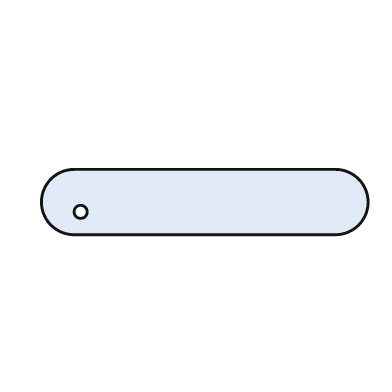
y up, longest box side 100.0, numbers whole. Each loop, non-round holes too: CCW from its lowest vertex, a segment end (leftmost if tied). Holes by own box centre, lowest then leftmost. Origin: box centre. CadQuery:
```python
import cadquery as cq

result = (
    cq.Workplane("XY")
    .moveTo(-40.0, -10.0)
    .lineTo(40.0, -10.0)
    .threePointArc((50.0, 0.0), (40.0, 10.0))
    .lineTo(-40.0, 10.0)
    .threePointArc((-50.0, 0.0), (-40.0, -10.0))
    .close()
    .moveTo(-38.0, -3.0)
    .circle(2.0)
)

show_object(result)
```